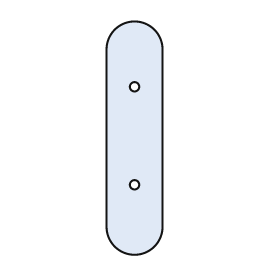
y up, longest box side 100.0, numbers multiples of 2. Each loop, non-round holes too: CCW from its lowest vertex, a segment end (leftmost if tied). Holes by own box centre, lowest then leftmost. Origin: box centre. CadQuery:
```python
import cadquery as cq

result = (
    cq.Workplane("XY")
    .moveTo(-12.0, -38.0)
    .threePointArc((0.0, -50.0), (12.0, -38.0))
    .lineTo(12.0, 38.0)
    .threePointArc((0.0, 50.0), (-12.0, 38.0))
    .close()
    .moveTo(0.0, -20.0)
    .circle(2.0)
    .moveTo(0.0, 22.0)
    .circle(2.0)
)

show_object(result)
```